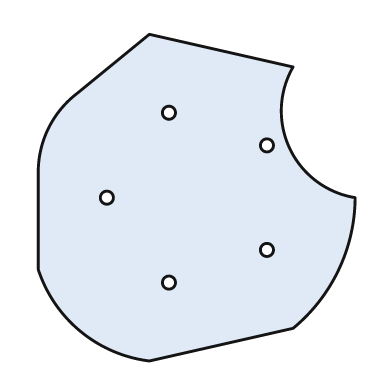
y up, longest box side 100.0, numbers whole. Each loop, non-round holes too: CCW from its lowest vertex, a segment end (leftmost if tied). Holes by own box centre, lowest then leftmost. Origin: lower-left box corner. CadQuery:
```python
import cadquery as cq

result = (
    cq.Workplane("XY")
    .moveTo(34.0, 0.0)
    .lineTo(78.0, 10.0)
    .threePointArc((92.0, 28.0), (97.0, 50.0))
    .threePointArc((77.0, 65.0), (78.0, 90.0))
    .lineTo(34.0, 100.0)
    .lineTo(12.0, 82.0)
    .threePointArc((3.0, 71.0), (0.0, 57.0))
    .lineTo(0.0, 28.0)
    .threePointArc((13.0, 9.0), (34.0, 0.0))
    .close()
    .moveTo(40.0, 24.0)
    .circle(2.0)
    .moveTo(70.0, 34.0)
    .circle(2.0)
    .moveTo(21.0, 50.0)
    .circle(2.0)
    .moveTo(70.0, 66.0)
    .circle(2.0)
    .moveTo(40.0, 76.0)
    .circle(2.0)
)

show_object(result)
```